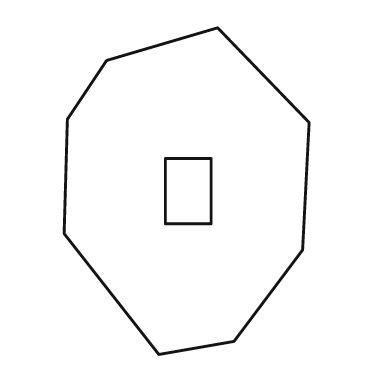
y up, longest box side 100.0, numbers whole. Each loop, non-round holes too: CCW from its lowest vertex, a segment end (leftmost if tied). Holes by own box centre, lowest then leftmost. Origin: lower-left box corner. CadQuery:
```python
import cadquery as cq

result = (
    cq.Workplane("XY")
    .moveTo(29.0, 0.0)
    .lineTo(52.0, 4.0)
    .lineTo(73.0, 32.0)
    .lineTo(75.0, 71.0)
    .lineTo(47.0, 100.0)
    .lineTo(13.0, 90.0)
    .lineTo(1.0, 72.0)
    .lineTo(0.0, 37.0)
    .close()
    .moveTo(31.0, 40.0)
    .lineTo(45.0, 40.0)
    .lineTo(45.0, 60.0)
    .lineTo(31.0, 60.0)
    .close()
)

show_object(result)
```